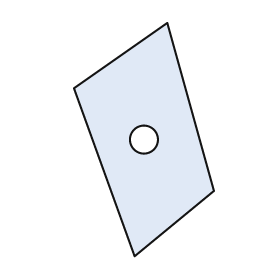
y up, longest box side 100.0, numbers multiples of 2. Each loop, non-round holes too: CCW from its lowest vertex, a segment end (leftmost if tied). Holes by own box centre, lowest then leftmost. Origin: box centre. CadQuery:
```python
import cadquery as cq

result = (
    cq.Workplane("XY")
    .moveTo(-4.0, -50.0)
    .lineTo(30.0, -22.0)
    .lineTo(10.0, 50.0)
    .lineTo(-30.0, 22.0)
    .close()
    .moveTo(0.0, 0.0)
    .circle(6.0)
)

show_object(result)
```